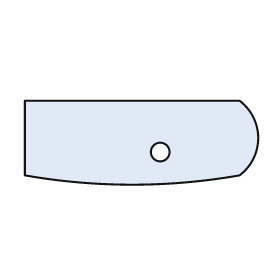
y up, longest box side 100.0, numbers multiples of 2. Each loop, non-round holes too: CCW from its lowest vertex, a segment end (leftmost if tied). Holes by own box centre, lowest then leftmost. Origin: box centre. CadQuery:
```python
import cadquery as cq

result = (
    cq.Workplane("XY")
    .moveTo(-50.0, -14.0)
    .threePointArc((-4.0, -18.0), (42.0, -14.0))
    .threePointArc((50.0, 2.0), (42.0, 18.0))
    .lineTo(-50.0, 18.0)
    .close()
    .moveTo(8.0, -4.0)
    .circle(4.0)
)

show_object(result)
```